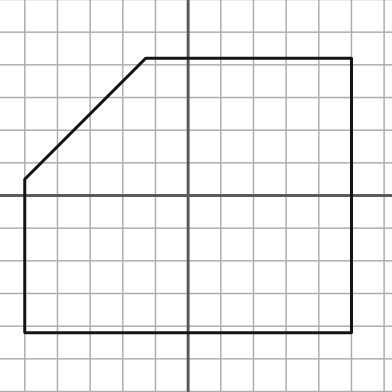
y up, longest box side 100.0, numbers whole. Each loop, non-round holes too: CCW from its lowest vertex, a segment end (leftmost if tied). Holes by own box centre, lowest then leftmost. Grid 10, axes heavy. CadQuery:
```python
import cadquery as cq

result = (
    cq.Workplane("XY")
    .moveTo(-50.0, -42.0)
    .lineTo(50.0, -42.0)
    .lineTo(50.0, 42.0)
    .lineTo(-13.0, 42.0)
    .lineTo(-50.0, 5.0)
    .close()
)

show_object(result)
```